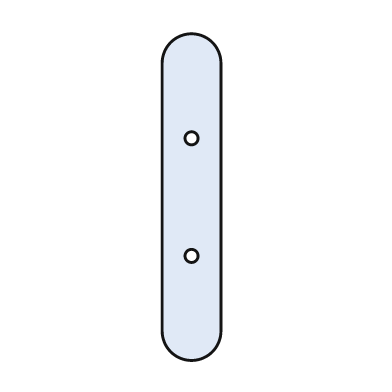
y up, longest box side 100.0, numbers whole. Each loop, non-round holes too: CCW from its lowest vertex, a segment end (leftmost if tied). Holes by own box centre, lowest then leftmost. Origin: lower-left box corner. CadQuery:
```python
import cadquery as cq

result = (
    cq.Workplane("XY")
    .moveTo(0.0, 9.0)
    .threePointArc((9.0, 0.0), (18.0, 9.0))
    .lineTo(18.0, 91.0)
    .threePointArc((9.0, 100.0), (0.0, 91.0))
    .close()
    .moveTo(9.0, 32.0)
    .circle(2.0)
    .moveTo(9.0, 68.0)
    .circle(2.0)
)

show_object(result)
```